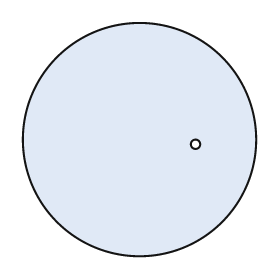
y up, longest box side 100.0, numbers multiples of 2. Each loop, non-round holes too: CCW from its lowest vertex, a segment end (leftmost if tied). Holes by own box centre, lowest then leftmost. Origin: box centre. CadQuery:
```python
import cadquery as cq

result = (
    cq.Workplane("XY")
    .moveTo(0.0, 0.0)
    .circle(50.0)
    .moveTo(24.0, -2.0)
    .circle(2.0)
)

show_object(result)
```